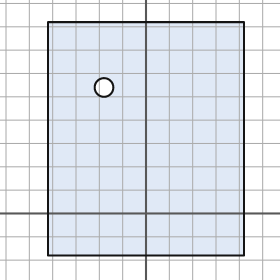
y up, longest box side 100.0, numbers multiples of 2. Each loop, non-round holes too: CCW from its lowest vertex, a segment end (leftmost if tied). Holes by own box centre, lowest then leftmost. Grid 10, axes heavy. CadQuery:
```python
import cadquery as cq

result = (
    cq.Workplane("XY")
    .moveTo(-42.0, -18.0)
    .lineTo(42.0, -18.0)
    .lineTo(42.0, 82.0)
    .lineTo(-42.0, 82.0)
    .close()
    .moveTo(-18.0, 54.0)
    .circle(4.0)
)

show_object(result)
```